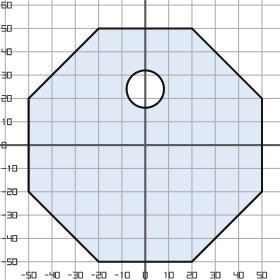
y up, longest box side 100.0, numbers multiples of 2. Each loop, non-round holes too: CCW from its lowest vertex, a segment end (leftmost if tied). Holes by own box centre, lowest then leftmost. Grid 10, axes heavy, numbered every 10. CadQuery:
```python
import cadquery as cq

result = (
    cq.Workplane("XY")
    .moveTo(-20.0, -50.0)
    .lineTo(20.0, -50.0)
    .lineTo(50.0, -20.0)
    .lineTo(50.0, 20.0)
    .lineTo(20.0, 50.0)
    .lineTo(-20.0, 50.0)
    .lineTo(-50.0, 20.0)
    .lineTo(-50.0, -20.0)
    .close()
    .moveTo(0.0, 24.0)
    .circle(8.0)
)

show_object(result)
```